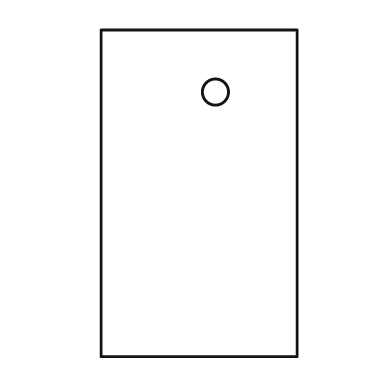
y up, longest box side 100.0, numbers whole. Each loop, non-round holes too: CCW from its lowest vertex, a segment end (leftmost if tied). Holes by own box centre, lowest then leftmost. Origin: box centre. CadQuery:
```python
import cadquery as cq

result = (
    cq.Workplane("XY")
    .moveTo(-30.0, -50.0)
    .lineTo(30.0, -50.0)
    .lineTo(30.0, 50.0)
    .lineTo(-30.0, 50.0)
    .close()
    .moveTo(5.0, 31.0)
    .circle(4.0)
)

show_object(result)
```